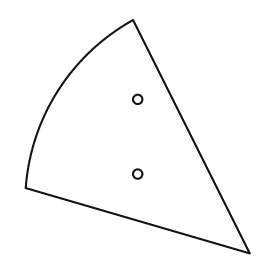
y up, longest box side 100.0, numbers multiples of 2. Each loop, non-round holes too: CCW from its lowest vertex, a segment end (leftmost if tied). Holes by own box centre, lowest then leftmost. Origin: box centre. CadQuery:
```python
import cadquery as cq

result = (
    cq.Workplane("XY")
    .moveTo(48.0, -50.0)
    .lineTo(-2.0, 50.0)
    .threePointArc((-34.0, 20.0), (-48.0, -22.0))
    .close()
    .moveTo(0.0, -16.0)
    .circle(2.0)
    .moveTo(0.0, 16.0)
    .circle(2.0)
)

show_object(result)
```